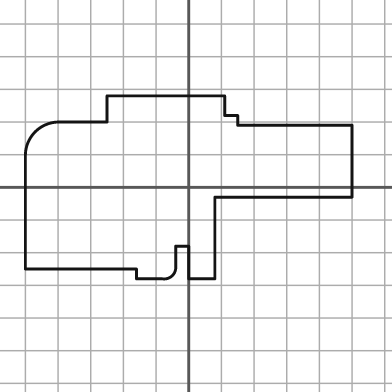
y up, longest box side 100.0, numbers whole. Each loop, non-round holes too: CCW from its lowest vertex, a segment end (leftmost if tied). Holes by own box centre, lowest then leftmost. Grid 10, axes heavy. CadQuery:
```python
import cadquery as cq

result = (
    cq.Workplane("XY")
    .moveTo(-16.0, -28.0)
    .lineTo(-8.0, -28.0)
    .threePointArc((-5.0, -27.0), (-4.0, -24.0))
    .lineTo(-4.0, -18.0)
    .lineTo(0.0, -18.0)
    .lineTo(0.0, -28.0)
    .lineTo(8.0, -28.0)
    .lineTo(8.0, -3.0)
    .lineTo(50.0, -3.0)
    .lineTo(50.0, 19.0)
    .lineTo(15.0, 19.0)
    .lineTo(15.0, 22.0)
    .lineTo(11.0, 22.0)
    .lineTo(11.0, 28.0)
    .lineTo(-25.0, 28.0)
    .lineTo(-25.0, 20.0)
    .lineTo(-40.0, 20.0)
    .threePointArc((-47.0, 17.0), (-50.0, 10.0))
    .lineTo(-50.0, -25.0)
    .lineTo(-16.0, -25.0)
    .close()
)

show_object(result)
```